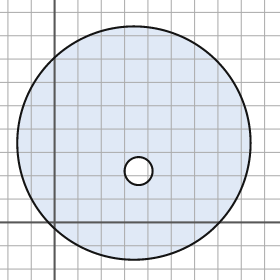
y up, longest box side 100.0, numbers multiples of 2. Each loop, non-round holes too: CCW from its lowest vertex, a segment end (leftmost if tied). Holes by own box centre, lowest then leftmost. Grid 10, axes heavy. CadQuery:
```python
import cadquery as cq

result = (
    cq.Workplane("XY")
    .moveTo(34.0, 34.0)
    .circle(50.0)
    .moveTo(36.0, 22.0)
    .circle(6.0)
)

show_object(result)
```